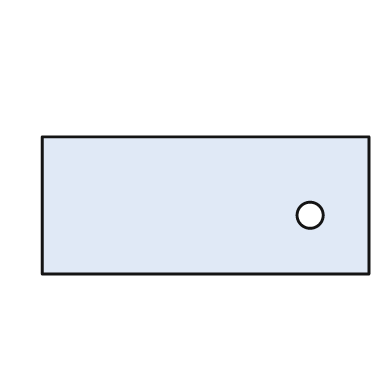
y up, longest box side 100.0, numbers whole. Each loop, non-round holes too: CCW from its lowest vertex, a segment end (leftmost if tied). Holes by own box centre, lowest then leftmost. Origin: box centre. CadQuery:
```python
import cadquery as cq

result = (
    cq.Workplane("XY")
    .moveTo(-50.0, -21.0)
    .lineTo(50.0, -21.0)
    .lineTo(50.0, 21.0)
    .lineTo(-50.0, 21.0)
    .close()
    .moveTo(32.0, -3.0)
    .circle(4.0)
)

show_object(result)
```